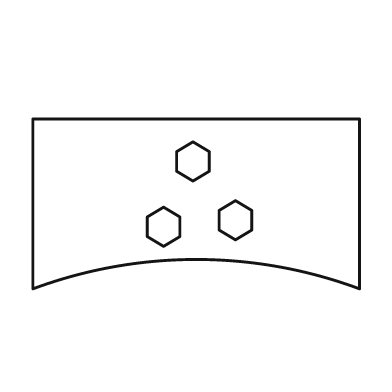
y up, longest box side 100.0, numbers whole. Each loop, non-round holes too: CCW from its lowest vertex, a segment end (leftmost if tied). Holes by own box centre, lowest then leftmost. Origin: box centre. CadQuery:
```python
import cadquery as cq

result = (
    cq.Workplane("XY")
    .moveTo(-50.0, -26.0)
    .threePointArc((0.0, -17.0), (50.0, -26.0))
    .lineTo(50.0, 26.0)
    .lineTo(-50.0, 26.0)
    .close()
    .moveTo(-10.0, -13.0)
    .lineTo(-5.0, -10.0)
    .lineTo(-5.0, -4.0)
    .lineTo(-10.0, -1.0)
    .lineTo(-15.0, -4.0)
    .lineTo(-15.0, -10.0)
    .close()
    .moveTo(12.0, -11.0)
    .lineTo(17.0, -8.0)
    .lineTo(17.0, -2.0)
    .lineTo(12.0, 1.0)
    .lineTo(7.0, -2.0)
    .lineTo(7.0, -8.0)
    .close()
    .moveTo(-1.0, 7.0)
    .lineTo(4.0, 10.0)
    .lineTo(4.0, 16.0)
    .lineTo(-1.0, 19.0)
    .lineTo(-6.0, 16.0)
    .lineTo(-6.0, 10.0)
    .close()
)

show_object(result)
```